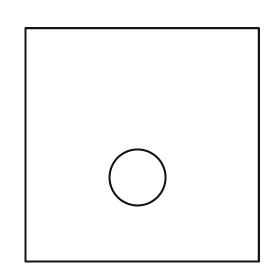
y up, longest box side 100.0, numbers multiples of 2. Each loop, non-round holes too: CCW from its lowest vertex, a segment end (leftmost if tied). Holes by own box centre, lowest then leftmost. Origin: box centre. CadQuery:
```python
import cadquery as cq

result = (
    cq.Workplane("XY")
    .moveTo(-50.0, -50.0)
    .lineTo(50.0, -50.0)
    .lineTo(50.0, 50.0)
    .lineTo(-50.0, 50.0)
    .close()
    .moveTo(-2.0, -14.0)
    .circle(12.0)
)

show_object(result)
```